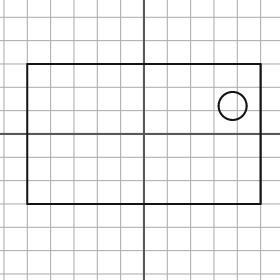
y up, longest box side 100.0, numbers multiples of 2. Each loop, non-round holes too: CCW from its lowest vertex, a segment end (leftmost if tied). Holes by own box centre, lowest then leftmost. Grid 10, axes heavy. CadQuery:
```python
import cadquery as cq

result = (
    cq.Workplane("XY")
    .moveTo(-50.0, -30.0)
    .lineTo(50.0, -30.0)
    .lineTo(50.0, 30.0)
    .lineTo(-50.0, 30.0)
    .close()
    .moveTo(38.0, 12.0)
    .circle(6.0)
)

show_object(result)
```